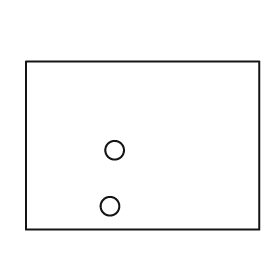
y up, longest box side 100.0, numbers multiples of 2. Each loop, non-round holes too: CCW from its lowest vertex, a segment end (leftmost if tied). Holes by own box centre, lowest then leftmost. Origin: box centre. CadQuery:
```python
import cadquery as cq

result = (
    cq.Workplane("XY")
    .moveTo(-50.0, -36.0)
    .lineTo(50.0, -36.0)
    .lineTo(50.0, 36.0)
    .lineTo(-50.0, 36.0)
    .close()
    .moveTo(-14.0, -26.0)
    .circle(4.0)
    .moveTo(-12.0, -2.0)
    .circle(4.0)
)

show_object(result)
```